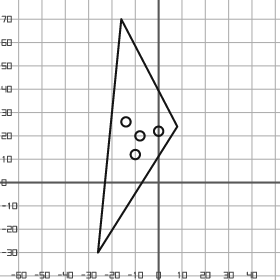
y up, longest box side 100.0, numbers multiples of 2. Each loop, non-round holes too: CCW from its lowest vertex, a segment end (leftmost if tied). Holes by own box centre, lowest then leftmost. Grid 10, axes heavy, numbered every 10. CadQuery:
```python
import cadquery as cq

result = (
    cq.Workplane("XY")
    .moveTo(-26.0, -30.0)
    .lineTo(8.0, 24.0)
    .lineTo(-16.0, 70.0)
    .close()
    .moveTo(-10.0, 12.0)
    .circle(2.0)
    .moveTo(-8.0, 20.0)
    .circle(2.0)
    .moveTo(0.0, 22.0)
    .circle(2.0)
    .moveTo(-14.0, 26.0)
    .circle(2.0)
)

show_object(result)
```